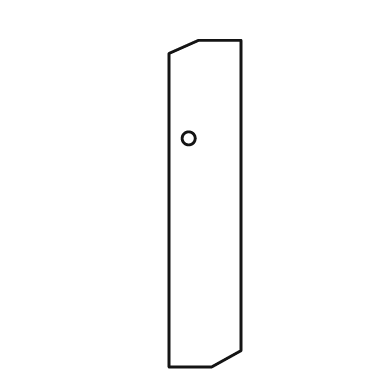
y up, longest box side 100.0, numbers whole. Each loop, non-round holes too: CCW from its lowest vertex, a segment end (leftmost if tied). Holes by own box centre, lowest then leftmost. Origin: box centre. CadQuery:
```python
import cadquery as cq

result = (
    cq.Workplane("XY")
    .moveTo(-11.0, -50.0)
    .lineTo(2.0, -50.0)
    .lineTo(11.0, -45.0)
    .lineTo(11.0, 50.0)
    .lineTo(-2.0, 50.0)
    .lineTo(-11.0, 46.0)
    .close()
    .moveTo(-5.0, 20.0)
    .circle(2.0)
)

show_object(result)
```